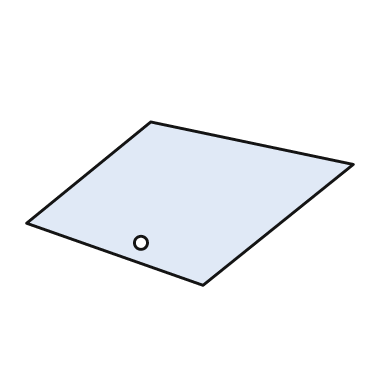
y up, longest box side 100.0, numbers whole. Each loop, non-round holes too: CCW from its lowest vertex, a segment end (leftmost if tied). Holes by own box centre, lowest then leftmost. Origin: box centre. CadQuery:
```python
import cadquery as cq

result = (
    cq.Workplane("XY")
    .moveTo(4.0, -25.0)
    .lineTo(50.0, 12.0)
    .lineTo(-12.0, 25.0)
    .lineTo(-50.0, -6.0)
    .close()
    .moveTo(-15.0, -12.0)
    .circle(2.0)
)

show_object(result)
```